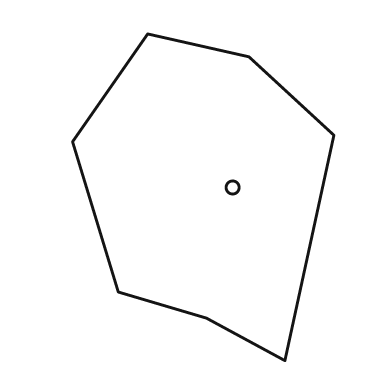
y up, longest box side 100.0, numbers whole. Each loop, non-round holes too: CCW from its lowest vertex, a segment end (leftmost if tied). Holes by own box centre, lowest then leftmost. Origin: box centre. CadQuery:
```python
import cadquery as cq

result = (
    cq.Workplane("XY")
    .moveTo(25.0, -50.0)
    .lineTo(40.0, 19.0)
    .lineTo(14.0, 43.0)
    .lineTo(-17.0, 50.0)
    .lineTo(-40.0, 17.0)
    .lineTo(-26.0, -29.0)
    .lineTo(1.0, -37.0)
    .close()
    .moveTo(9.0, 3.0)
    .circle(2.0)
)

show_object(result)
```